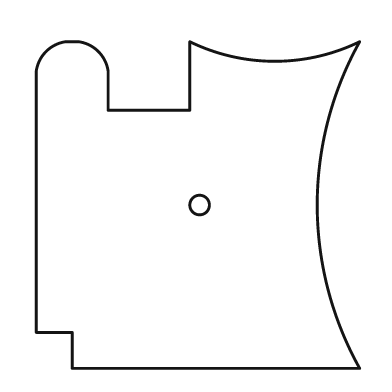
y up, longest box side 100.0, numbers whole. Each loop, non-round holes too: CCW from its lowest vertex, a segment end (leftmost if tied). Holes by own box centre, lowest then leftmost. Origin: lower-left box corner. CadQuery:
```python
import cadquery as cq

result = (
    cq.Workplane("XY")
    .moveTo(11.0, 0.0)
    .lineTo(99.0, 0.0)
    .threePointArc((86.0, 50.0), (99.0, 100.0))
    .threePointArc((73.0, 94.0), (47.0, 100.0))
    .lineTo(47.0, 79.0)
    .lineTo(22.0, 79.0)
    .lineTo(22.0, 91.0)
    .threePointArc((19.0, 97.0), (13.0, 100.0))
    .lineTo(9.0, 100.0)
    .threePointArc((3.0, 97.0), (0.0, 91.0))
    .lineTo(0.0, 11.0)
    .lineTo(11.0, 11.0)
    .close()
    .moveTo(50.0, 50.0)
    .circle(3.0)
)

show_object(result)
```